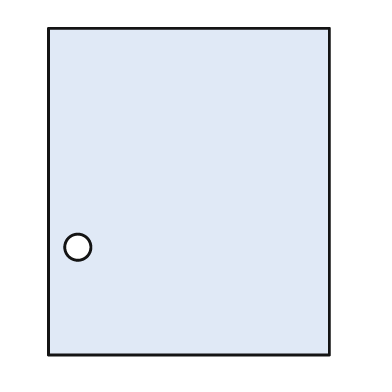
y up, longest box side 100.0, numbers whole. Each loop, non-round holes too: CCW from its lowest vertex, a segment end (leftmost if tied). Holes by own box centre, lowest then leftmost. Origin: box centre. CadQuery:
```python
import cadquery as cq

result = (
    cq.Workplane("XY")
    .moveTo(-43.0, -50.0)
    .lineTo(43.0, -50.0)
    .lineTo(43.0, 50.0)
    .lineTo(-43.0, 50.0)
    .close()
    .moveTo(-34.0, -17.0)
    .circle(4.0)
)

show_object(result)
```